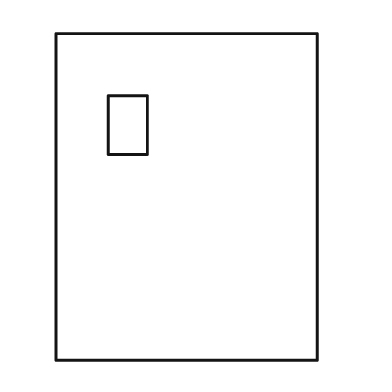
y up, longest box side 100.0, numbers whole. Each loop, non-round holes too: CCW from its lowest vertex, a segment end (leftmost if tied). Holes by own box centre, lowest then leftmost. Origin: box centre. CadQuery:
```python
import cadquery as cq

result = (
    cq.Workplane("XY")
    .moveTo(-40.0, -50.0)
    .lineTo(40.0, -50.0)
    .lineTo(40.0, 50.0)
    .lineTo(-40.0, 50.0)
    .close()
    .moveTo(-24.0, 13.0)
    .lineTo(-12.0, 13.0)
    .lineTo(-12.0, 31.0)
    .lineTo(-24.0, 31.0)
    .close()
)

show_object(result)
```